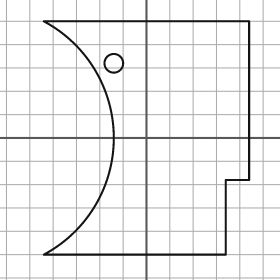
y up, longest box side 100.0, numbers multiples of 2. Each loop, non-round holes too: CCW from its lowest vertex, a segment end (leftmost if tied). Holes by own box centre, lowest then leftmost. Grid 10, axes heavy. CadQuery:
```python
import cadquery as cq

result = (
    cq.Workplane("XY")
    .moveTo(-44.0, -50.0)
    .lineTo(34.0, -50.0)
    .lineTo(34.0, -18.0)
    .lineTo(44.0, -18.0)
    .lineTo(44.0, 50.0)
    .lineTo(-44.0, 50.0)
    .threePointArc((-14.0, 0.0), (-44.0, -50.0))
    .close()
    .moveTo(-14.0, 32.0)
    .circle(4.0)
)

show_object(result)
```